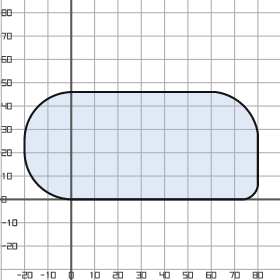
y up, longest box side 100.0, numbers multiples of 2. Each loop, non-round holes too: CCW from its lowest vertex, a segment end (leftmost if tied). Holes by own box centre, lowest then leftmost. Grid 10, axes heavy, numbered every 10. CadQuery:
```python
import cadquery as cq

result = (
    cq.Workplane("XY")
    .moveTo(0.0, 0.0)
    .lineTo(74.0, 0.0)
    .threePointArc((78.0, 2.0), (80.0, 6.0))
    .lineTo(80.0, 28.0)
    .threePointArc((74.0, 40.0), (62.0, 46.0))
    .lineTo(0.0, 46.0)
    .threePointArc((-14.0, 40.0), (-20.0, 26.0))
    .lineTo(-20.0, 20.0)
    .threePointArc((-14.0, 6.0), (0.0, 0.0))
    .close()
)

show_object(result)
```